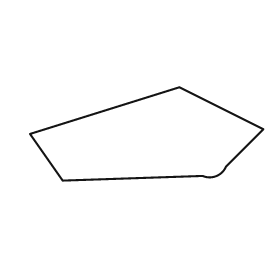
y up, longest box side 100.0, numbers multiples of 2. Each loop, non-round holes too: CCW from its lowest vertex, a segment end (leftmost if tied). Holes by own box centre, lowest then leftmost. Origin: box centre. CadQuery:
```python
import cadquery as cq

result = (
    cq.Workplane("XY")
    .moveTo(-36.0, -20.0)
    .lineTo(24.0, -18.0)
    .threePointArc((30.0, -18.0), (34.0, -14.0))
    .lineTo(50.0, 2.0)
    .lineTo(14.0, 20.0)
    .lineTo(-50.0, 0.0)
    .close()
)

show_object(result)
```